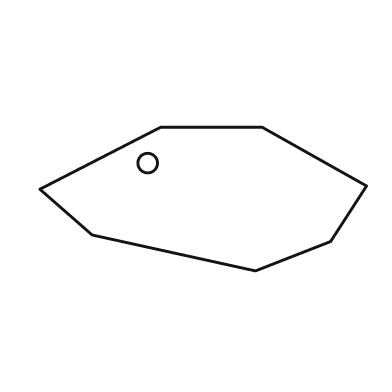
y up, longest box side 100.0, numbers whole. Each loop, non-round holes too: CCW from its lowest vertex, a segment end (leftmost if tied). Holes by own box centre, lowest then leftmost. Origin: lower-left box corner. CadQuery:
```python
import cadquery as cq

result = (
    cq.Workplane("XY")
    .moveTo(66.0, 0.0)
    .lineTo(89.0, 9.0)
    .lineTo(100.0, 26.0)
    .lineTo(68.0, 44.0)
    .lineTo(37.0, 44.0)
    .lineTo(0.0, 25.0)
    .lineTo(16.0, 11.0)
    .close()
    .moveTo(33.0, 33.0)
    .circle(3.0)
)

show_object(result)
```